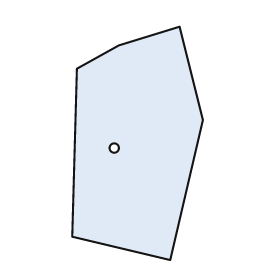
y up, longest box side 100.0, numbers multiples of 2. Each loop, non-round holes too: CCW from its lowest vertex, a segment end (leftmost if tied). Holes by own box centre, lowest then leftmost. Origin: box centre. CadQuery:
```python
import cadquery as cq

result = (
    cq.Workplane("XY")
    .moveTo(14.0, -50.0)
    .lineTo(28.0, 10.0)
    .lineTo(18.0, 50.0)
    .lineTo(-8.0, 42.0)
    .lineTo(-26.0, 32.0)
    .lineTo(-28.0, -40.0)
    .close()
    .moveTo(-10.0, -2.0)
    .circle(2.0)
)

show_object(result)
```